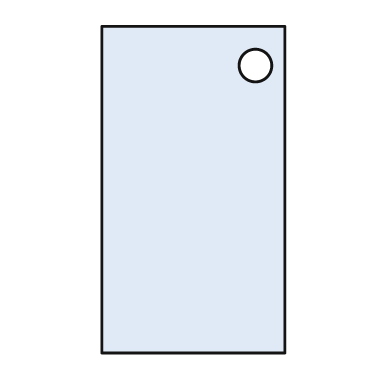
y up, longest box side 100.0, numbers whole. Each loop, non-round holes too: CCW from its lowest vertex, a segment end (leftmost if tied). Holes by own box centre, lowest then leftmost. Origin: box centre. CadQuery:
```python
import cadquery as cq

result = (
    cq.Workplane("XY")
    .moveTo(-28.0, -50.0)
    .lineTo(28.0, -50.0)
    .lineTo(28.0, 50.0)
    .lineTo(-28.0, 50.0)
    .close()
    .moveTo(19.0, 38.0)
    .circle(5.0)
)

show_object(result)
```